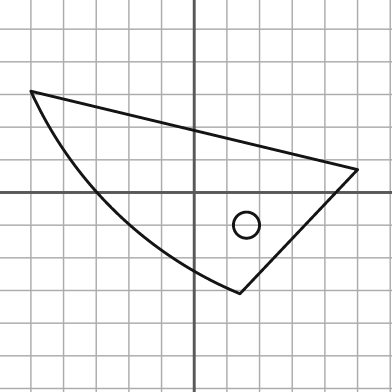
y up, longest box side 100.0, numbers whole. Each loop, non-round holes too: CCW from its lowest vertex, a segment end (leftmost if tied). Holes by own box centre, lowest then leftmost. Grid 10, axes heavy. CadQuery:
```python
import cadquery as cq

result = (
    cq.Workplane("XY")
    .moveTo(14.0, -31.0)
    .lineTo(50.0, 7.0)
    .lineTo(-50.0, 31.0)
    .threePointArc((-24.0, -6.0), (14.0, -31.0))
    .close()
    .moveTo(16.0, -10.0)
    .circle(4.0)
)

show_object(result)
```